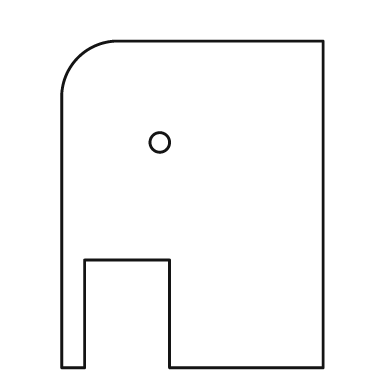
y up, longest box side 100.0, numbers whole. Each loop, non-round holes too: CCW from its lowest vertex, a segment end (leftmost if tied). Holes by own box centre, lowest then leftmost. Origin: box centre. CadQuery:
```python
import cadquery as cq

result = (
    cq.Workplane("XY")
    .moveTo(-40.0, -50.0)
    .lineTo(-33.0, -50.0)
    .lineTo(-33.0, -17.0)
    .lineTo(-7.0, -17.0)
    .lineTo(-7.0, -50.0)
    .lineTo(40.0, -50.0)
    .lineTo(40.0, 50.0)
    .lineTo(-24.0, 50.0)
    .threePointArc((-35.0, 45.0), (-40.0, 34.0))
    .close()
    .moveTo(-10.0, 19.0)
    .circle(3.0)
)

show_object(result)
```